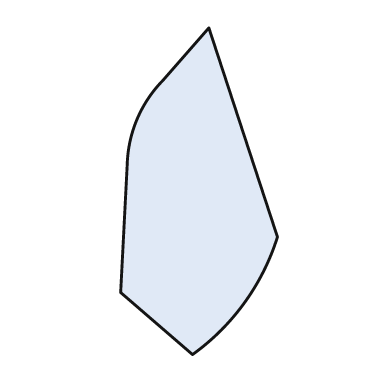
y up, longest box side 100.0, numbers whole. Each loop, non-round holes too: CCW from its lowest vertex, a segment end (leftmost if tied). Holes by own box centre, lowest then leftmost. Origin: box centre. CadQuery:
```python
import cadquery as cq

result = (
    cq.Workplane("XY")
    .moveTo(-2.0, -50.0)
    .threePointArc((14.0, -34.0), (24.0, -14.0))
    .lineTo(3.0, 50.0)
    .lineTo(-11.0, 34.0)
    .threePointArc((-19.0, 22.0), (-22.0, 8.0))
    .lineTo(-24.0, -31.0)
    .close()
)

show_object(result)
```